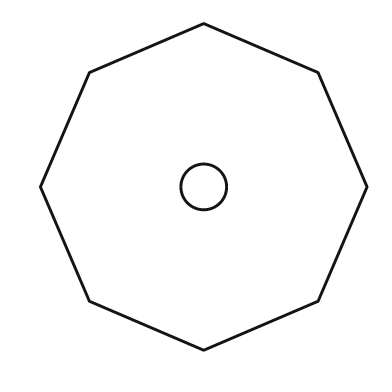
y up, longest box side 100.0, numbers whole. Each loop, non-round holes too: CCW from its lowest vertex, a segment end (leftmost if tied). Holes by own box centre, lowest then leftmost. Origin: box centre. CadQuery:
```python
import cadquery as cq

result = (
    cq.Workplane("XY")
    .moveTo(0.0, -50.0)
    .lineTo(35.0, -35.0)
    .lineTo(50.0, 0.0)
    .lineTo(35.0, 35.0)
    .lineTo(0.0, 50.0)
    .lineTo(-35.0, 35.0)
    .lineTo(-50.0, 0.0)
    .lineTo(-35.0, -35.0)
    .close()
    .moveTo(0.0, 0.0)
    .circle(7.0)
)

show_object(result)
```